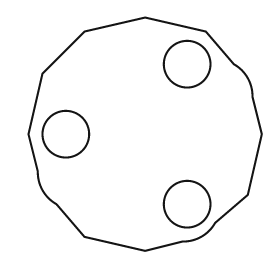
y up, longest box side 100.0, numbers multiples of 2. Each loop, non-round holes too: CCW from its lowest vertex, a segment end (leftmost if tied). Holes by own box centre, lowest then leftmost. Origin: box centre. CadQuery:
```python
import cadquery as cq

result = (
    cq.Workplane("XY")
    .moveTo(0.0, -50.0)
    .lineTo(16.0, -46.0)
    .threePointArc((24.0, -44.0), (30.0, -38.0))
    .lineTo(44.0, -26.0)
    .lineTo(50.0, 0.0)
    .lineTo(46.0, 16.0)
    .threePointArc((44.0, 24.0), (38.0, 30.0))
    .lineTo(26.0, 44.0)
    .lineTo(0.0, 50.0)
    .lineTo(-26.0, 44.0)
    .lineTo(-44.0, 26.0)
    .lineTo(-50.0, 0.0)
    .lineTo(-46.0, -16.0)
    .threePointArc((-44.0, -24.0), (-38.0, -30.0))
    .lineTo(-26.0, -44.0)
    .close()
    .moveTo(18.0, -30.0)
    .circle(10.0)
    .moveTo(-34.0, 0.0)
    .circle(10.0)
    .moveTo(18.0, 30.0)
    .circle(10.0)
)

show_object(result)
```